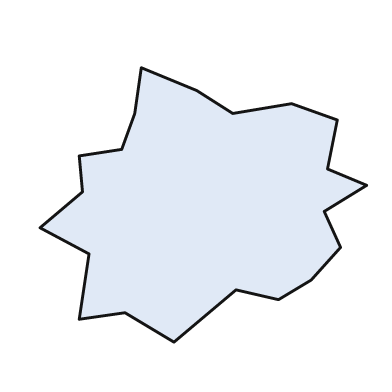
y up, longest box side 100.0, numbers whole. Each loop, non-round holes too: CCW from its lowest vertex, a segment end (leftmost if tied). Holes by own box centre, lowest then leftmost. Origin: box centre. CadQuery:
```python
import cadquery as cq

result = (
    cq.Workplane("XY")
    .moveTo(-9.0, -42.0)
    .lineTo(10.0, -26.0)
    .lineTo(23.0, -29.0)
    .lineTo(33.0, -23.0)
    .lineTo(42.0, -13.0)
    .lineTo(37.0, -2.0)
    .lineTo(50.0, 6.0)
    .lineTo(38.0, 11.0)
    .lineTo(41.0, 26.0)
    .lineTo(27.0, 31.0)
    .lineTo(9.0, 28.0)
    .lineTo(-2.0, 35.0)
    .lineTo(-19.0, 42.0)
    .lineTo(-21.0, 28.0)
    .lineTo(-25.0, 17.0)
    .lineTo(-38.0, 15.0)
    .lineTo(-37.0, 4.0)
    .lineTo(-50.0, -7.0)
    .lineTo(-35.0, -15.0)
    .lineTo(-38.0, -35.0)
    .lineTo(-24.0, -33.0)
    .close()
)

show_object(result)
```